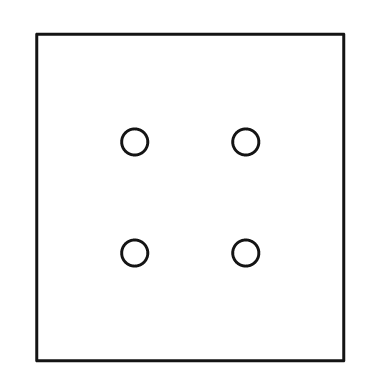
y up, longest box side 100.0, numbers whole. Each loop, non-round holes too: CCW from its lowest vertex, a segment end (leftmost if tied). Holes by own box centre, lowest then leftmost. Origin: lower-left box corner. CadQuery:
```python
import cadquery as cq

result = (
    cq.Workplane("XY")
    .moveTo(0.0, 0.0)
    .lineTo(94.0, 0.0)
    .lineTo(94.0, 100.0)
    .lineTo(0.0, 100.0)
    .close()
    .moveTo(30.0, 33.0)
    .circle(4.0)
    .moveTo(64.0, 33.0)
    .circle(4.0)
    .moveTo(30.0, 67.0)
    .circle(4.0)
    .moveTo(64.0, 67.0)
    .circle(4.0)
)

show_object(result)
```